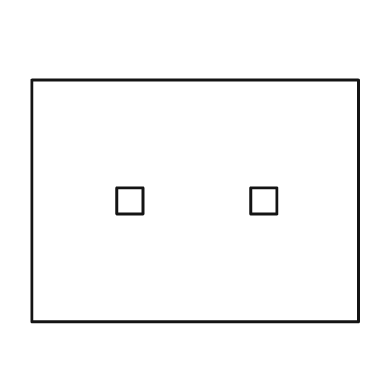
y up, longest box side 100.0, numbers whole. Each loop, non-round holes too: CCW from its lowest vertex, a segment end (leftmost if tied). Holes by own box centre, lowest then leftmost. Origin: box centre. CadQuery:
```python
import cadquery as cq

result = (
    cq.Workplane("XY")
    .moveTo(-50.0, -37.0)
    .lineTo(50.0, -37.0)
    .lineTo(50.0, 37.0)
    .lineTo(-50.0, 37.0)
    .close()
    .moveTo(-24.0, -4.0)
    .lineTo(-16.0, -4.0)
    .lineTo(-16.0, 4.0)
    .lineTo(-24.0, 4.0)
    .close()
    .moveTo(17.0, -4.0)
    .lineTo(25.0, -4.0)
    .lineTo(25.0, 4.0)
    .lineTo(17.0, 4.0)
    .close()
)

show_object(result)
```